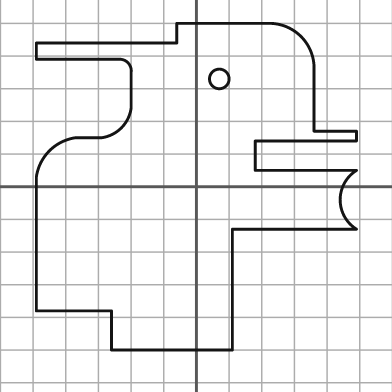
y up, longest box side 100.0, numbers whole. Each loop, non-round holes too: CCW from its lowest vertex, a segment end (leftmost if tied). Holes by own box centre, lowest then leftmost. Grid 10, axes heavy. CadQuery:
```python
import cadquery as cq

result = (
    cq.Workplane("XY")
    .moveTo(-26.0, -50.0)
    .lineTo(11.0, -50.0)
    .lineTo(11.0, -13.0)
    .lineTo(49.0, -13.0)
    .threePointArc((44.0, -4.0), (49.0, 5.0))
    .lineTo(18.0, 5.0)
    .lineTo(18.0, 14.0)
    .lineTo(49.0, 14.0)
    .lineTo(49.0, 17.0)
    .lineTo(36.0, 17.0)
    .lineTo(36.0, 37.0)
    .threePointArc((32.0, 46.0), (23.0, 50.0))
    .lineTo(-6.0, 50.0)
    .lineTo(-6.0, 44.0)
    .lineTo(-49.0, 44.0)
    .lineTo(-49.0, 39.0)
    .lineTo(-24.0, 39.0)
    .threePointArc((-21.0, 38.0), (-20.0, 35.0))
    .lineTo(-20.0, 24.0)
    .threePointArc((-23.0, 18.0), (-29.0, 15.0))
    .lineTo(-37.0, 15.0)
    .threePointArc((-45.0, 11.0), (-49.0, 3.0))
    .lineTo(-49.0, -38.0)
    .lineTo(-26.0, -38.0)
    .close()
    .moveTo(7.0, 33.0)
    .circle(3.0)
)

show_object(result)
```